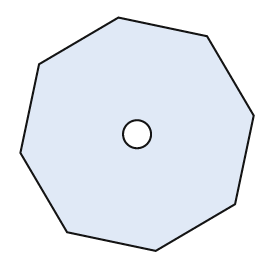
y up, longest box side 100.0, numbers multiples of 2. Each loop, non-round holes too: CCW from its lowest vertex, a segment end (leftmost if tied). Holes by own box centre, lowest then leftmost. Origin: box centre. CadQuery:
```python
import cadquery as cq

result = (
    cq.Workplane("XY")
    .moveTo(8.0, -50.0)
    .lineTo(42.0, -30.0)
    .lineTo(50.0, 8.0)
    .lineTo(30.0, 42.0)
    .lineTo(-8.0, 50.0)
    .lineTo(-42.0, 30.0)
    .lineTo(-50.0, -8.0)
    .lineTo(-30.0, -42.0)
    .close()
    .moveTo(0.0, 0.0)
    .circle(6.0)
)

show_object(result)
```